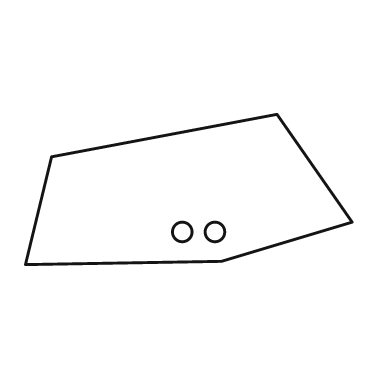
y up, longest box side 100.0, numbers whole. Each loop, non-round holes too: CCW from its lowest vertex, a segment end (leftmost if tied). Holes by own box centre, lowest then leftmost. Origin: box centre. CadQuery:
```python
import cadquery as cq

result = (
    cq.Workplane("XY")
    .moveTo(-50.0, -23.0)
    .lineTo(10.0, -22.0)
    .lineTo(50.0, -10.0)
    .lineTo(27.0, 23.0)
    .lineTo(-42.0, 10.0)
    .close()
    .moveTo(-2.0, -13.0)
    .circle(3.0)
    .moveTo(8.0, -13.0)
    .circle(3.0)
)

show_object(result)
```